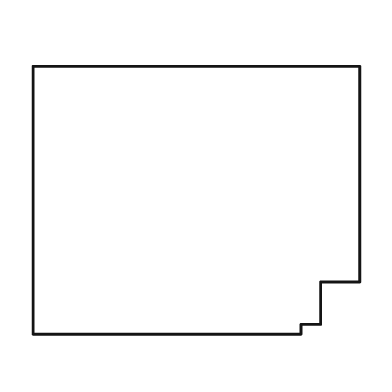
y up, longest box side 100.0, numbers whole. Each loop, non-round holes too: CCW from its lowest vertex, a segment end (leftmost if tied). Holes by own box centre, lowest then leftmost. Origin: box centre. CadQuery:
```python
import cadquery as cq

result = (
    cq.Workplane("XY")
    .moveTo(-50.0, -41.0)
    .lineTo(32.0, -41.0)
    .lineTo(32.0, -38.0)
    .lineTo(38.0, -38.0)
    .lineTo(38.0, -25.0)
    .lineTo(50.0, -25.0)
    .lineTo(50.0, 41.0)
    .lineTo(-50.0, 41.0)
    .close()
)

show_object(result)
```